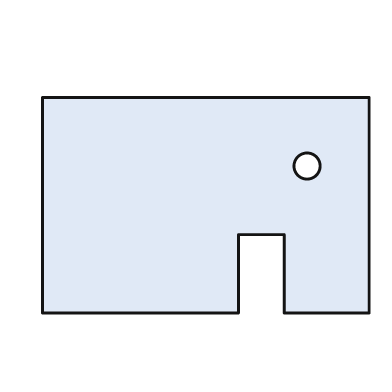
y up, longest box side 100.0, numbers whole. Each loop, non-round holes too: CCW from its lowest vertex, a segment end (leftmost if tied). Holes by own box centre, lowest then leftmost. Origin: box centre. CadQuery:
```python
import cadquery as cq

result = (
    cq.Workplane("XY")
    .moveTo(-50.0, -33.0)
    .lineTo(10.0, -33.0)
    .lineTo(10.0, -9.0)
    .lineTo(24.0, -9.0)
    .lineTo(24.0, -33.0)
    .lineTo(50.0, -33.0)
    .lineTo(50.0, 33.0)
    .lineTo(-50.0, 33.0)
    .close()
    .moveTo(31.0, 12.0)
    .circle(4.0)
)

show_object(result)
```